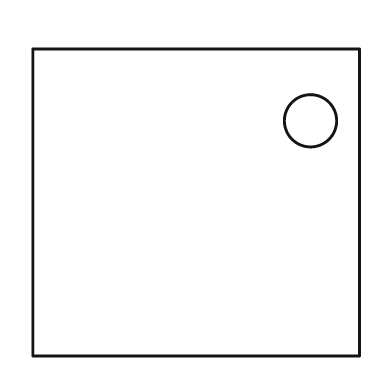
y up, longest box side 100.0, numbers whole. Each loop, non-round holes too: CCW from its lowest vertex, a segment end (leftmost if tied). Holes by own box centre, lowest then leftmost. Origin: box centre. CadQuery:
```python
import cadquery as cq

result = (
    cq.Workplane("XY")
    .moveTo(-50.0, -47.0)
    .lineTo(50.0, -47.0)
    .lineTo(50.0, 47.0)
    .lineTo(-50.0, 47.0)
    .close()
    .moveTo(35.0, 25.0)
    .circle(8.0)
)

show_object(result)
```